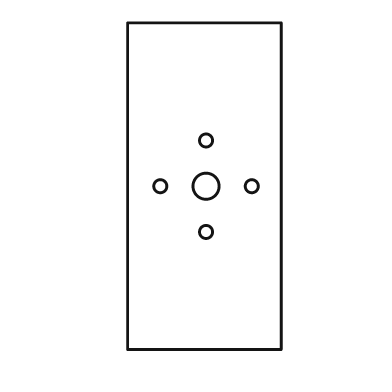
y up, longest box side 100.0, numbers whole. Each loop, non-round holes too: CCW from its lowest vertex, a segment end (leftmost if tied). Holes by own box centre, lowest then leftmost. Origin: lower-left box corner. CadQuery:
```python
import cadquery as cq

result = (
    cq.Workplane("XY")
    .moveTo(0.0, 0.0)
    .lineTo(47.0, 0.0)
    .lineTo(47.0, 100.0)
    .lineTo(0.0, 100.0)
    .close()
    .moveTo(24.0, 36.0)
    .circle(2.0)
    .moveTo(10.0, 50.0)
    .circle(2.0)
    .moveTo(24.0, 50.0)
    .circle(4.0)
    .moveTo(38.0, 50.0)
    .circle(2.0)
    .moveTo(24.0, 64.0)
    .circle(2.0)
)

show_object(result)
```